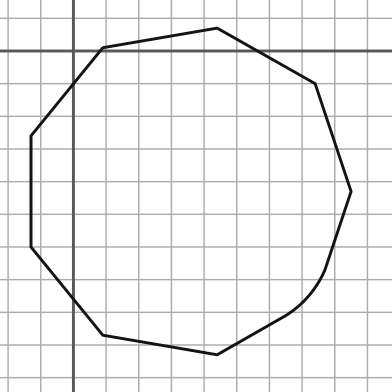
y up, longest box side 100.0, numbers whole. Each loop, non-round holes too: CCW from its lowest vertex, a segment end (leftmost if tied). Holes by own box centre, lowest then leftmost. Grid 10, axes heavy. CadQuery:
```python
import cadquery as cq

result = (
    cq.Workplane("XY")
    .moveTo(44.0, -93.0)
    .lineTo(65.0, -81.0)
    .threePointArc((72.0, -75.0), (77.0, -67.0))
    .lineTo(85.0, -43.0)
    .lineTo(74.0, -10.0)
    .lineTo(44.0, 7.0)
    .lineTo(9.0, 1.0)
    .lineTo(-13.0, -26.0)
    .lineTo(-13.0, -60.0)
    .lineTo(9.0, -87.0)
    .close()
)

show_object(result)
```